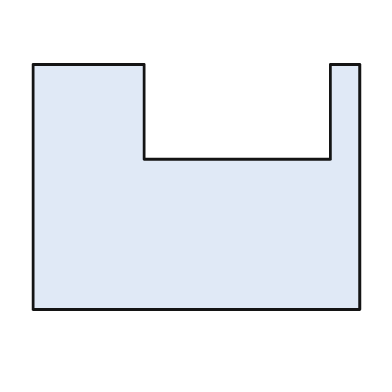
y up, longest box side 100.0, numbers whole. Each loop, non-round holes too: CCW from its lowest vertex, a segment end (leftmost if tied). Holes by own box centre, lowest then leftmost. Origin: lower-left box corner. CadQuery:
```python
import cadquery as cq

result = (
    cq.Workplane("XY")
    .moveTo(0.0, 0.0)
    .lineTo(100.0, 0.0)
    .lineTo(100.0, 75.0)
    .lineTo(91.0, 75.0)
    .lineTo(91.0, 46.0)
    .lineTo(34.0, 46.0)
    .lineTo(34.0, 75.0)
    .lineTo(0.0, 75.0)
    .close()
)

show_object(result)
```